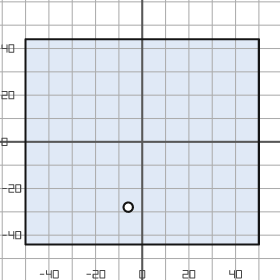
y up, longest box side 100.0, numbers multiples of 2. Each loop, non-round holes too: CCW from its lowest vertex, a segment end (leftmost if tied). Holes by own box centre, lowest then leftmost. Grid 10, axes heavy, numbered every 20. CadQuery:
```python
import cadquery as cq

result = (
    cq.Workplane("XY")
    .moveTo(-50.0, -44.0)
    .lineTo(50.0, -44.0)
    .lineTo(50.0, 44.0)
    .lineTo(-50.0, 44.0)
    .close()
    .moveTo(-6.0, -28.0)
    .circle(2.0)
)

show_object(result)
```